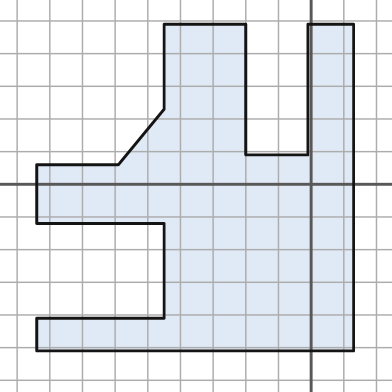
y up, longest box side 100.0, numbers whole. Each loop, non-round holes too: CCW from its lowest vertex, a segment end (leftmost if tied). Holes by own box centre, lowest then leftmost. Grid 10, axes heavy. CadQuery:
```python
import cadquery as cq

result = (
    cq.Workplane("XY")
    .moveTo(-84.0, -51.0)
    .lineTo(13.0, -51.0)
    .lineTo(13.0, 49.0)
    .lineTo(-1.0, 49.0)
    .lineTo(-1.0, 9.0)
    .lineTo(-20.0, 9.0)
    .lineTo(-20.0, 49.0)
    .lineTo(-45.0, 49.0)
    .lineTo(-45.0, 23.0)
    .lineTo(-59.0, 6.0)
    .lineTo(-84.0, 6.0)
    .lineTo(-84.0, -12.0)
    .lineTo(-45.0, -12.0)
    .lineTo(-45.0, -41.0)
    .lineTo(-84.0, -41.0)
    .close()
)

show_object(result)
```